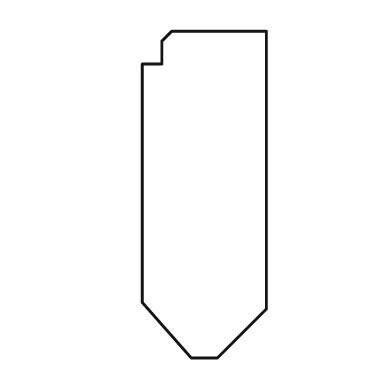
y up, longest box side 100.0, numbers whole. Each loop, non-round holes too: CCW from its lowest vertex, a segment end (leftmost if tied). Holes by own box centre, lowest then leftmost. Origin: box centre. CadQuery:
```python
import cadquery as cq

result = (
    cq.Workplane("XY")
    .moveTo(-4.0, -50.0)
    .lineTo(4.0, -50.0)
    .lineTo(19.0, -35.0)
    .lineTo(19.0, 50.0)
    .lineTo(-10.0, 50.0)
    .lineTo(-13.0, 47.0)
    .lineTo(-13.0, 40.0)
    .lineTo(-19.0, 40.0)
    .lineTo(-19.0, -33.0)
    .close()
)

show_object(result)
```